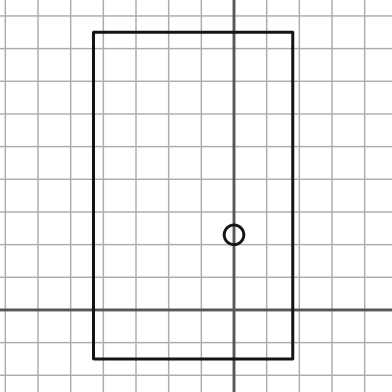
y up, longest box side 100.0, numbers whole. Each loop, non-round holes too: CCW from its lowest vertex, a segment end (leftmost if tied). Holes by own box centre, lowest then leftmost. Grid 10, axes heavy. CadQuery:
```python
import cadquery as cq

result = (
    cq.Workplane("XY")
    .moveTo(-43.0, -15.0)
    .lineTo(18.0, -15.0)
    .lineTo(18.0, 85.0)
    .lineTo(-43.0, 85.0)
    .close()
    .moveTo(0.0, 23.0)
    .circle(3.0)
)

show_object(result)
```